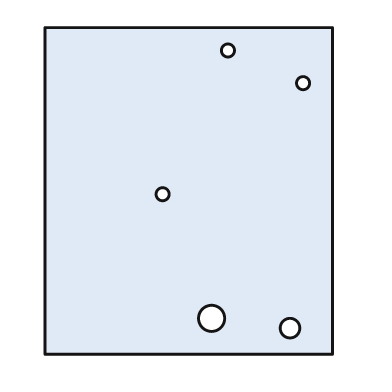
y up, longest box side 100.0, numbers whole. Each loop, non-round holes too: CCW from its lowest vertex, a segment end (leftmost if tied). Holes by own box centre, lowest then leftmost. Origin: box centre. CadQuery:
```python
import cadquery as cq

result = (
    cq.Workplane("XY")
    .moveTo(-44.0, -50.0)
    .lineTo(44.0, -50.0)
    .lineTo(44.0, 50.0)
    .lineTo(-44.0, 50.0)
    .close()
    .moveTo(31.0, -42.0)
    .circle(3.0)
    .moveTo(7.0, -39.0)
    .circle(4.0)
    .moveTo(-8.0, -1.0)
    .circle(2.0)
    .moveTo(35.0, 33.0)
    .circle(2.0)
    .moveTo(12.0, 43.0)
    .circle(2.0)
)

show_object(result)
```